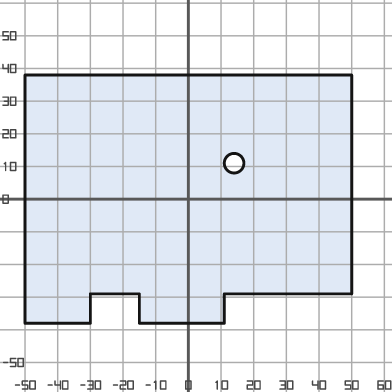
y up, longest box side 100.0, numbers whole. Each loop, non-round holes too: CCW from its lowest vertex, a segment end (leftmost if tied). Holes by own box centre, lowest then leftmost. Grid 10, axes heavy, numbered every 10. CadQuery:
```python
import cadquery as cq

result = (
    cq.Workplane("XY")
    .moveTo(-50.0, -38.0)
    .lineTo(-30.0, -38.0)
    .lineTo(-30.0, -29.0)
    .lineTo(-15.0, -29.0)
    .lineTo(-15.0, -38.0)
    .lineTo(11.0, -38.0)
    .lineTo(11.0, -29.0)
    .lineTo(50.0, -29.0)
    .lineTo(50.0, 38.0)
    .lineTo(-50.0, 38.0)
    .close()
    .moveTo(14.0, 11.0)
    .circle(3.0)
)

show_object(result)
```